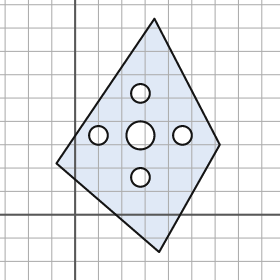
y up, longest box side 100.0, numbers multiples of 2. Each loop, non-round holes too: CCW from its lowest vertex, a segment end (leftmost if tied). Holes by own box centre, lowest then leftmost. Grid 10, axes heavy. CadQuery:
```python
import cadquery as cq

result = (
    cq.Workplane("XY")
    .moveTo(36.0, -16.0)
    .lineTo(62.0, 30.0)
    .lineTo(34.0, 84.0)
    .lineTo(-8.0, 22.0)
    .close()
    .moveTo(28.0, 16.0)
    .circle(4.0)
    .moveTo(10.0, 34.0)
    .circle(4.0)
    .moveTo(28.0, 34.0)
    .circle(6.0)
    .moveTo(46.0, 34.0)
    .circle(4.0)
    .moveTo(28.0, 52.0)
    .circle(4.0)
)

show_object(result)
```